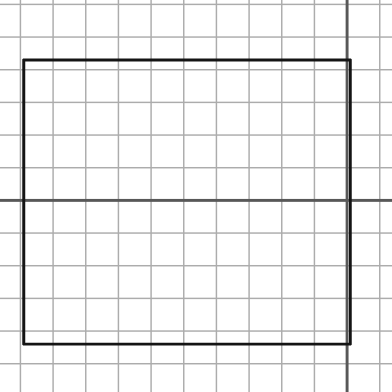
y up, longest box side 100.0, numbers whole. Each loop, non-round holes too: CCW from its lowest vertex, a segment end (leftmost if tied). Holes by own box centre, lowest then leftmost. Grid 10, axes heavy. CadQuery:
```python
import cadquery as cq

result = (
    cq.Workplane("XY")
    .moveTo(-99.0, -44.0)
    .lineTo(1.0, -44.0)
    .lineTo(1.0, 43.0)
    .lineTo(-99.0, 43.0)
    .close()
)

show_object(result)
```